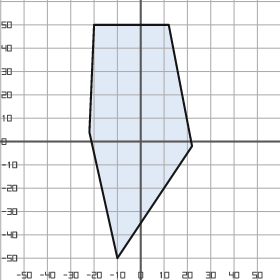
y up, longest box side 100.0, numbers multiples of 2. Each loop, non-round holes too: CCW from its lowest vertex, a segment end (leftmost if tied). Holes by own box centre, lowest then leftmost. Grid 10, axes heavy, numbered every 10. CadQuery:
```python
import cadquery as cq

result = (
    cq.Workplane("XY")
    .moveTo(-10.0, -50.0)
    .lineTo(22.0, -2.0)
    .lineTo(12.0, 50.0)
    .lineTo(-20.0, 50.0)
    .lineTo(-22.0, 4.0)
    .close()
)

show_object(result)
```